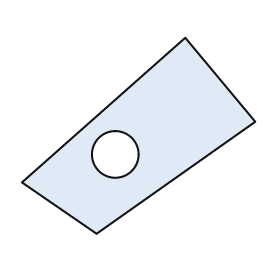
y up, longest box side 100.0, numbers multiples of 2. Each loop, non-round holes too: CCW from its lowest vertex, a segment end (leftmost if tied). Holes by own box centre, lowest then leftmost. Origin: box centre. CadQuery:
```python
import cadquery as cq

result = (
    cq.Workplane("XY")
    .moveTo(-18.0, -42.0)
    .lineTo(50.0, 6.0)
    .lineTo(20.0, 42.0)
    .lineTo(-50.0, -20.0)
    .close()
    .moveTo(-10.0, -8.0)
    .circle(10.0)
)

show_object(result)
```